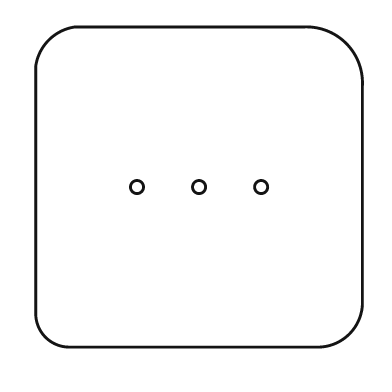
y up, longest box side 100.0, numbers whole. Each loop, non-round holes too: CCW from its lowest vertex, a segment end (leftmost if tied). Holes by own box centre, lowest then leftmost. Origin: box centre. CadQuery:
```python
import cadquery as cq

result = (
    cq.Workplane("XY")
    .moveTo(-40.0, -49.0)
    .lineTo(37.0, -49.0)
    .threePointArc((46.0, -45.0), (50.0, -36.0))
    .lineTo(50.0, 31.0)
    .threePointArc((45.0, 44.0), (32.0, 49.0))
    .lineTo(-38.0, 49.0)
    .threePointArc((-46.0, 45.0), (-50.0, 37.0))
    .lineTo(-50.0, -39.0)
    .threePointArc((-47.0, -46.0), (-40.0, -49.0))
    .close()
    .moveTo(-19.0, 0.0)
    .circle(2.0)
    .moveTo(0.0, 0.0)
    .circle(2.0)
    .moveTo(19.0, 0.0)
    .circle(2.0)
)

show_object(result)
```